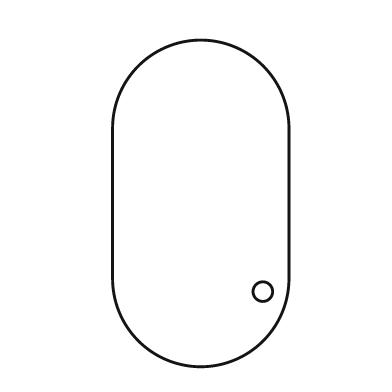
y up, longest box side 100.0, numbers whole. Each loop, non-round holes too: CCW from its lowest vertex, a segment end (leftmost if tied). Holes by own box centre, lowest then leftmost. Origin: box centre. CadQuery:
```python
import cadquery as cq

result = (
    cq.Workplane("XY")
    .moveTo(-27.0, -23.0)
    .threePointArc((0.0, -50.0), (27.0, -23.0))
    .lineTo(27.0, 23.0)
    .threePointArc((0.0, 50.0), (-27.0, 23.0))
    .close()
    .moveTo(19.0, -27.0)
    .circle(3.0)
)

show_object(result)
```